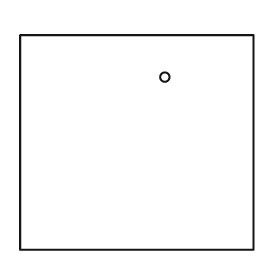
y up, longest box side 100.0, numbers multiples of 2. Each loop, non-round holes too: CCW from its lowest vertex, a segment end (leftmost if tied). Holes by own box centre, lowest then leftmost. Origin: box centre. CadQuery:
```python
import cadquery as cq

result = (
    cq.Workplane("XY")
    .moveTo(-50.0, -46.0)
    .lineTo(50.0, -46.0)
    .lineTo(50.0, 46.0)
    .lineTo(-50.0, 46.0)
    .close()
    .moveTo(12.0, 28.0)
    .circle(2.0)
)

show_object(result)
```